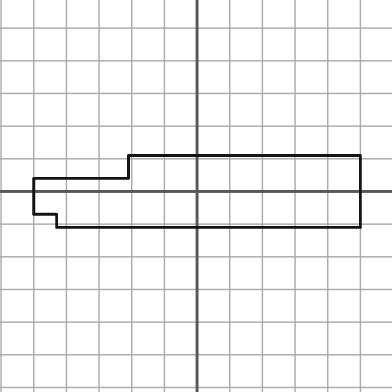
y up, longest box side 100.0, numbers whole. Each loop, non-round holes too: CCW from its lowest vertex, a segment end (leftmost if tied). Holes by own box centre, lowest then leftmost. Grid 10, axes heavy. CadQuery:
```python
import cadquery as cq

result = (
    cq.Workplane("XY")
    .moveTo(-43.0, -11.0)
    .lineTo(50.0, -11.0)
    .lineTo(50.0, 11.0)
    .lineTo(-21.0, 11.0)
    .lineTo(-21.0, 4.0)
    .lineTo(-50.0, 4.0)
    .lineTo(-50.0, -7.0)
    .lineTo(-43.0, -7.0)
    .close()
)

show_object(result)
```